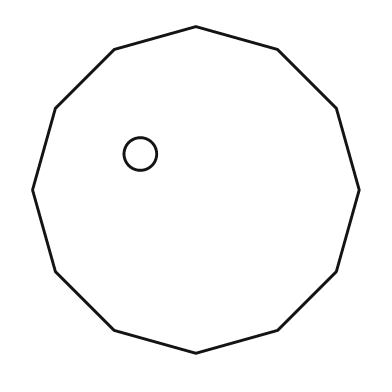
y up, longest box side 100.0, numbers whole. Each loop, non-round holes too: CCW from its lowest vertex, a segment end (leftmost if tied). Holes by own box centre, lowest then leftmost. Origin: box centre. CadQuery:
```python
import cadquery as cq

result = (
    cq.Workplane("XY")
    .moveTo(0.0, -50.0)
    .lineTo(25.0, -43.0)
    .lineTo(43.0, -25.0)
    .lineTo(50.0, 0.0)
    .lineTo(43.0, 25.0)
    .lineTo(25.0, 43.0)
    .lineTo(0.0, 50.0)
    .lineTo(-25.0, 43.0)
    .lineTo(-43.0, 25.0)
    .lineTo(-50.0, 0.0)
    .lineTo(-43.0, -25.0)
    .lineTo(-25.0, -43.0)
    .close()
    .moveTo(-17.0, 11.0)
    .circle(5.0)
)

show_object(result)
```